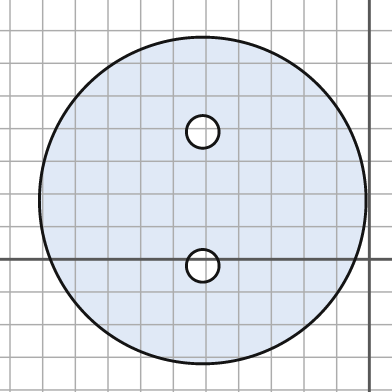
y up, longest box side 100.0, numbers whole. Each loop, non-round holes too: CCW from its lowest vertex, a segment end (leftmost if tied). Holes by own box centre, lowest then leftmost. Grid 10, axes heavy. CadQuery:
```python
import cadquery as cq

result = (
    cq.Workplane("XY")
    .moveTo(-51.0, 18.0)
    .circle(50.0)
    .moveTo(-51.0, -2.0)
    .circle(5.0)
    .moveTo(-51.0, 39.0)
    .circle(5.0)
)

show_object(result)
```